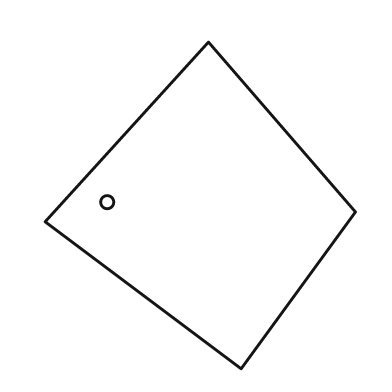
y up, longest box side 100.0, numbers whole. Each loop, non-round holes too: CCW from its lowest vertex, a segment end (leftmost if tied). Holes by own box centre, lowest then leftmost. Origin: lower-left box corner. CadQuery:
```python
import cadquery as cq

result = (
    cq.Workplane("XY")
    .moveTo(60.0, 0.0)
    .lineTo(95.0, 48.0)
    .lineTo(50.0, 100.0)
    .lineTo(0.0, 45.0)
    .close()
    .moveTo(19.0, 51.0)
    .circle(2.0)
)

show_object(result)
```